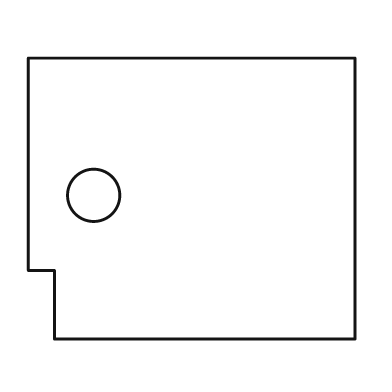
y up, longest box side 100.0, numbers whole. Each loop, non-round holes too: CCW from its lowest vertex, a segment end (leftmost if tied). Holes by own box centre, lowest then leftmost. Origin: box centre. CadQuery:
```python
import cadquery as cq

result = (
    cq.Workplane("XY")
    .moveTo(-42.0, -43.0)
    .lineTo(50.0, -43.0)
    .lineTo(50.0, 43.0)
    .lineTo(-50.0, 43.0)
    .lineTo(-50.0, -22.0)
    .lineTo(-42.0, -22.0)
    .close()
    .moveTo(-30.0, 1.0)
    .circle(8.0)
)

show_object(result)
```